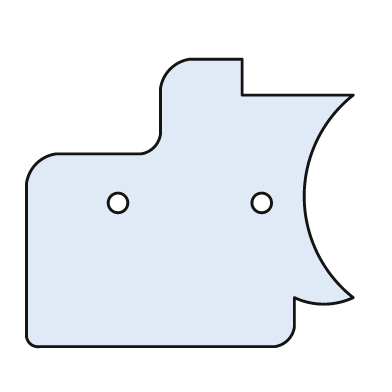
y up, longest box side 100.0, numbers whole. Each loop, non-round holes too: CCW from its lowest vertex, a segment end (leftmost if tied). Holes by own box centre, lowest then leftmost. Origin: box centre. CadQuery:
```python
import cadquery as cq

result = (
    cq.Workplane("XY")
    .moveTo(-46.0, -44.0)
    .lineTo(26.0, -44.0)
    .threePointArc((30.0, -42.0), (32.0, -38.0))
    .lineTo(32.0, -29.0)
    .threePointArc((41.0, -31.0), (50.0, -29.0))
    .threePointArc((35.0, 2.0), (50.0, 33.0))
    .lineTo(16.0, 33.0)
    .lineTo(16.0, 44.0)
    .lineTo(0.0, 44.0)
    .threePointArc((-6.0, 41.0), (-9.0, 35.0))
    .lineTo(-9.0, 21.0)
    .threePointArc((-11.0, 17.0), (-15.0, 15.0))
    .lineTo(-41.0, 15.0)
    .threePointArc((-47.0, 12.0), (-50.0, 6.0))
    .lineTo(-50.0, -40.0)
    .threePointArc((-49.0, -43.0), (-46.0, -44.0))
    .close()
    .moveTo(-22.0, 0.0)
    .circle(3.0)
    .moveTo(22.0, 0.0)
    .circle(3.0)
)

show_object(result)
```